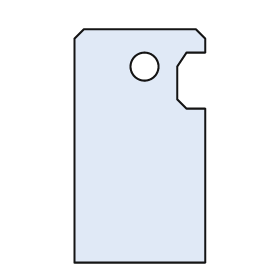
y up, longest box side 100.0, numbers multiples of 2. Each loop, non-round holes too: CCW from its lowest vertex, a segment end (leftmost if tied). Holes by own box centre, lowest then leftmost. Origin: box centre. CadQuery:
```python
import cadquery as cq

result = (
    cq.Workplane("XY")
    .moveTo(-28.0, -50.0)
    .lineTo(28.0, -50.0)
    .lineTo(28.0, 16.0)
    .lineTo(20.0, 16.0)
    .lineTo(16.0, 20.0)
    .lineTo(16.0, 34.0)
    .lineTo(20.0, 40.0)
    .lineTo(28.0, 40.0)
    .lineTo(28.0, 46.0)
    .lineTo(24.0, 50.0)
    .lineTo(-24.0, 50.0)
    .lineTo(-28.0, 46.0)
    .close()
    .moveTo(2.0, 34.0)
    .circle(6.0)
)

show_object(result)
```